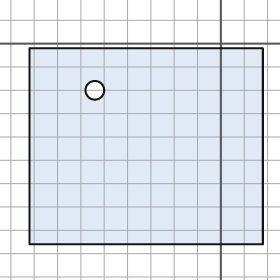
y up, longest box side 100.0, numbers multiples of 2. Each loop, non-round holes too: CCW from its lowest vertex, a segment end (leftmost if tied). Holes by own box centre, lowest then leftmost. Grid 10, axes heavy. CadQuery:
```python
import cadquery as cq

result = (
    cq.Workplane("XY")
    .moveTo(-82.0, -86.0)
    .lineTo(18.0, -86.0)
    .lineTo(18.0, -2.0)
    .lineTo(-82.0, -2.0)
    .close()
    .moveTo(-54.0, -20.0)
    .circle(4.0)
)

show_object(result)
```